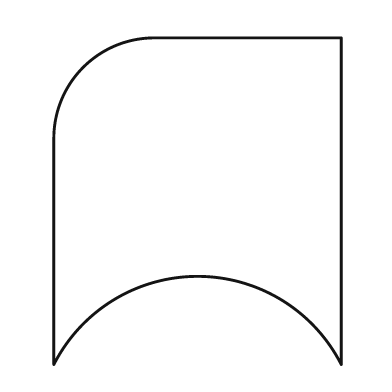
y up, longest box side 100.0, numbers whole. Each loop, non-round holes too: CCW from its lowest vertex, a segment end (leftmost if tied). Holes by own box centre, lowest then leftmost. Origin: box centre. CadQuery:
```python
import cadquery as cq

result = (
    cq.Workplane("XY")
    .moveTo(-44.0, -50.0)
    .threePointArc((0.0, -23.0), (44.0, -50.0))
    .lineTo(44.0, 50.0)
    .lineTo(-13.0, 50.0)
    .threePointArc((-35.0, 41.0), (-44.0, 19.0))
    .close()
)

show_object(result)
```